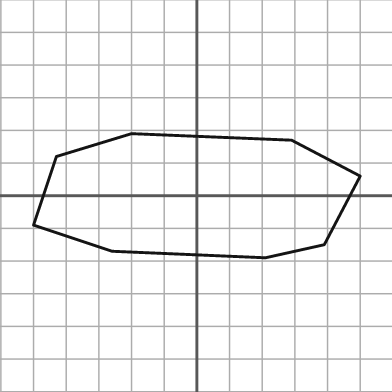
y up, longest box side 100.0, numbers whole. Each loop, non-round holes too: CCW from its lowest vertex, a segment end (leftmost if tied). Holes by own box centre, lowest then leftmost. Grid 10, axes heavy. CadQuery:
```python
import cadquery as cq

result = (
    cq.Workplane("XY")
    .moveTo(21.0, -19.0)
    .lineTo(39.0, -15.0)
    .lineTo(50.0, 6.0)
    .lineTo(29.0, 17.0)
    .lineTo(-20.0, 19.0)
    .lineTo(-43.0, 12.0)
    .lineTo(-50.0, -9.0)
    .lineTo(-26.0, -17.0)
    .close()
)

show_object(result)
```